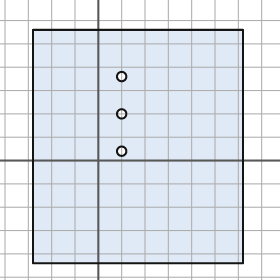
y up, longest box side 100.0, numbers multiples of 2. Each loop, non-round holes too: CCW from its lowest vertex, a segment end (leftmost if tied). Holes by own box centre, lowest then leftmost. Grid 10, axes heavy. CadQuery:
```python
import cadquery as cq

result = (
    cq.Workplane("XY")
    .moveTo(-28.0, -44.0)
    .lineTo(62.0, -44.0)
    .lineTo(62.0, 56.0)
    .lineTo(-28.0, 56.0)
    .close()
    .moveTo(10.0, 4.0)
    .circle(2.0)
    .moveTo(10.0, 20.0)
    .circle(2.0)
    .moveTo(10.0, 36.0)
    .circle(2.0)
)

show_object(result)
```